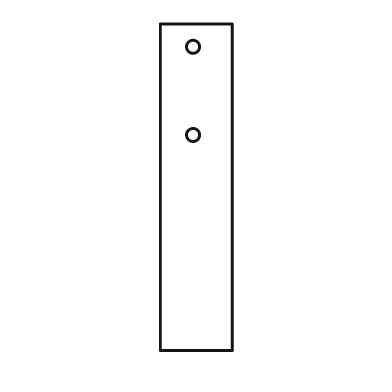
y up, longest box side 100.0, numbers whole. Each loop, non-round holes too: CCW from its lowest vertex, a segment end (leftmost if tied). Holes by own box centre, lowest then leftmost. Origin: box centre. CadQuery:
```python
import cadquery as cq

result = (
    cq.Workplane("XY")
    .moveTo(-11.0, -50.0)
    .lineTo(11.0, -50.0)
    .lineTo(11.0, 50.0)
    .lineTo(-11.0, 50.0)
    .close()
    .moveTo(-1.0, 16.0)
    .circle(2.0)
    .moveTo(-1.0, 43.0)
    .circle(2.0)
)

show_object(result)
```